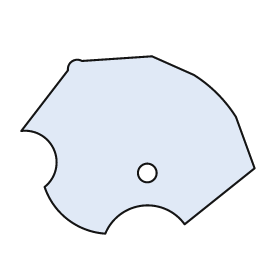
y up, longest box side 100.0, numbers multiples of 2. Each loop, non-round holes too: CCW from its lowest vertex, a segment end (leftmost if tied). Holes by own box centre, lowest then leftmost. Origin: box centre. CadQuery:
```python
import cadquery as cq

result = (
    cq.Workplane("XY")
    .moveTo(-14.0, -38.0)
    .threePointArc((2.0, -26.0), (20.0, -34.0))
    .lineTo(50.0, -10.0)
    .lineTo(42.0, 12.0)
    .threePointArc((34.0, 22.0), (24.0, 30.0))
    .lineTo(6.0, 38.0)
    .lineTo(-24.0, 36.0)
    .threePointArc((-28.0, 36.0), (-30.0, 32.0))
    .lineTo(-50.0, 6.0)
    .threePointArc((-36.0, -2.0), (-40.0, -18.0))
    .threePointArc((-30.0, -32.0), (-14.0, -38.0))
    .close()
    .moveTo(4.0, -12.0)
    .circle(4.0)
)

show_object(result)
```